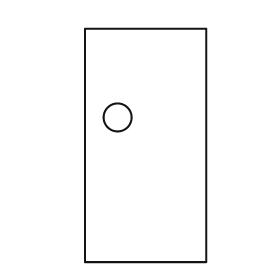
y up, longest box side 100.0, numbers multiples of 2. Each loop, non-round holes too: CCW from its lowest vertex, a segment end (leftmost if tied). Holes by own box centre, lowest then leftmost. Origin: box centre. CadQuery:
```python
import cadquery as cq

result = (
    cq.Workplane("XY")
    .moveTo(-26.0, -50.0)
    .lineTo(26.0, -50.0)
    .lineTo(26.0, 50.0)
    .lineTo(-26.0, 50.0)
    .close()
    .moveTo(-12.0, 12.0)
    .circle(6.0)
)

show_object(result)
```